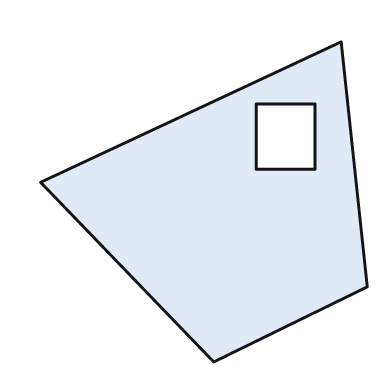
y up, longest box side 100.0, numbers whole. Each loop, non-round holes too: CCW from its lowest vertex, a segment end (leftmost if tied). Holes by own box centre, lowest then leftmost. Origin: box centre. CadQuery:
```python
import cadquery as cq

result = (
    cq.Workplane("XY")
    .moveTo(3.0, -49.0)
    .lineTo(50.0, -26.0)
    .lineTo(42.0, 49.0)
    .lineTo(-50.0, 6.0)
    .close()
    .moveTo(16.0, 10.0)
    .lineTo(34.0, 10.0)
    .lineTo(34.0, 30.0)
    .lineTo(16.0, 30.0)
    .close()
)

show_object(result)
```